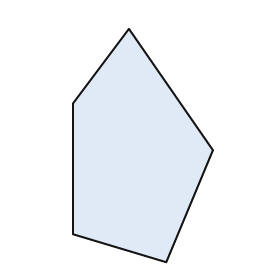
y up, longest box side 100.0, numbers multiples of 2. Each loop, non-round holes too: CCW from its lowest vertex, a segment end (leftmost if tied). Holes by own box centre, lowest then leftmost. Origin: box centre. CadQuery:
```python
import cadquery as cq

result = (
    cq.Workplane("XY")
    .moveTo(10.0, -50.0)
    .lineTo(30.0, -2.0)
    .lineTo(-6.0, 50.0)
    .lineTo(-30.0, 18.0)
    .lineTo(-30.0, -38.0)
    .close()
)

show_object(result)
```